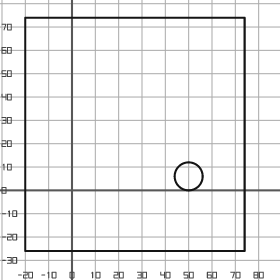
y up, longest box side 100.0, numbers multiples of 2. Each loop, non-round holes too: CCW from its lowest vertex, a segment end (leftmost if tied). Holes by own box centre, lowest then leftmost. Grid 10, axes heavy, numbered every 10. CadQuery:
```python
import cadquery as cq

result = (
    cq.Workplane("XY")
    .moveTo(-20.0, -26.0)
    .lineTo(74.0, -26.0)
    .lineTo(74.0, 74.0)
    .lineTo(-20.0, 74.0)
    .close()
    .moveTo(50.0, 6.0)
    .circle(6.0)
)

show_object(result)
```